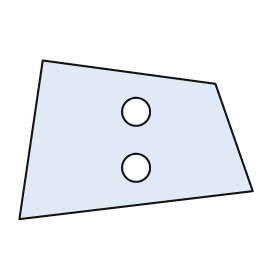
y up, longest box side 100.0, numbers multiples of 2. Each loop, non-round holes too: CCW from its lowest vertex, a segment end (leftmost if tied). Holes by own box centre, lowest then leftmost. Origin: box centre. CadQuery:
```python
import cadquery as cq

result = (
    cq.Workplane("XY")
    .moveTo(-50.0, -34.0)
    .lineTo(50.0, -22.0)
    .lineTo(34.0, 24.0)
    .lineTo(-40.0, 34.0)
    .close()
    .moveTo(0.0, -12.0)
    .circle(6.0)
    .moveTo(0.0, 12.0)
    .circle(6.0)
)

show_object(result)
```